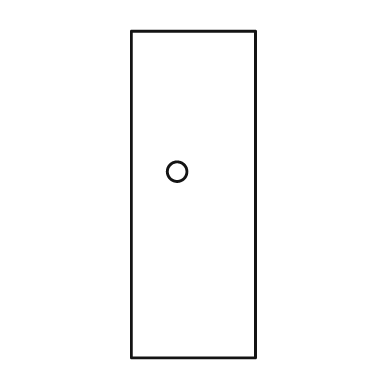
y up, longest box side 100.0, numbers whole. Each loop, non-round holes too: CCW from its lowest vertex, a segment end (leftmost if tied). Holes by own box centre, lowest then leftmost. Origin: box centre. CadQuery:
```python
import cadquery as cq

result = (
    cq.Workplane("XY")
    .moveTo(-19.0, -50.0)
    .lineTo(19.0, -50.0)
    .lineTo(19.0, 50.0)
    .lineTo(-19.0, 50.0)
    .close()
    .moveTo(-5.0, 7.0)
    .circle(3.0)
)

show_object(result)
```